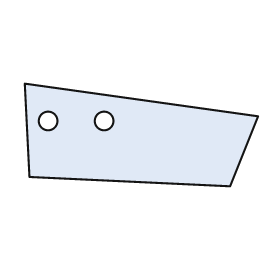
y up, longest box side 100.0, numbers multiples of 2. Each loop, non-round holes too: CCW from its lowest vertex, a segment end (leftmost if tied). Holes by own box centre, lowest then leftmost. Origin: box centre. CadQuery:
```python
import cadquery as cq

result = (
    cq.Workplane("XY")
    .moveTo(38.0, -22.0)
    .lineTo(50.0, 8.0)
    .lineTo(-50.0, 22.0)
    .lineTo(-48.0, -18.0)
    .close()
    .moveTo(-40.0, 6.0)
    .circle(4.0)
    .moveTo(-16.0, 6.0)
    .circle(4.0)
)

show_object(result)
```